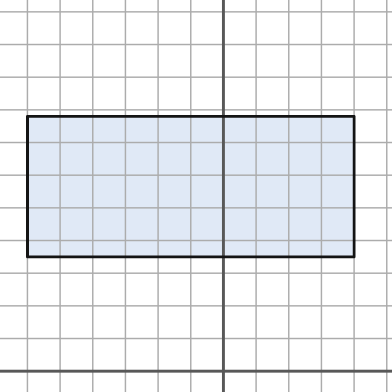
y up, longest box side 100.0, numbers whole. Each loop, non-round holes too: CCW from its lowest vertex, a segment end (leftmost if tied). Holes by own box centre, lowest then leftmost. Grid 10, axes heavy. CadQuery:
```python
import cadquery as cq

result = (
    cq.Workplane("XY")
    .moveTo(-60.0, 35.0)
    .lineTo(40.0, 35.0)
    .lineTo(40.0, 78.0)
    .lineTo(-60.0, 78.0)
    .close()
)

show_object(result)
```